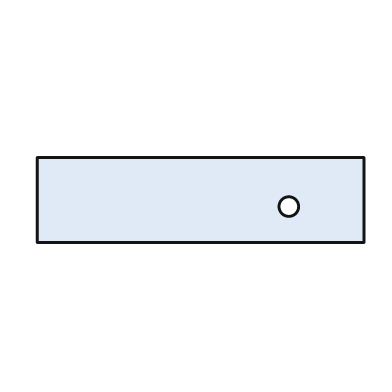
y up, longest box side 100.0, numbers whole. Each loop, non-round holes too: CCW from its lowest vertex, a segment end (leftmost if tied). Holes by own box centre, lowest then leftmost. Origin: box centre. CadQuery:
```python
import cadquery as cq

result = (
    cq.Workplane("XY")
    .moveTo(-50.0, -13.0)
    .lineTo(50.0, -13.0)
    .lineTo(50.0, 13.0)
    .lineTo(-50.0, 13.0)
    .close()
    .moveTo(27.0, -2.0)
    .circle(3.0)
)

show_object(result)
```